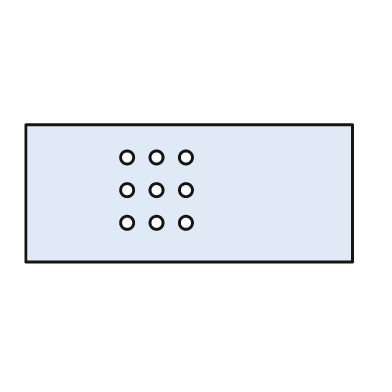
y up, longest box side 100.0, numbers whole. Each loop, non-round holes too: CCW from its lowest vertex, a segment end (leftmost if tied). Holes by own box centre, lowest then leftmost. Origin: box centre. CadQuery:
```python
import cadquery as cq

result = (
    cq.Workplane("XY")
    .moveTo(-50.0, -21.0)
    .lineTo(50.0, -21.0)
    .lineTo(50.0, 21.0)
    .lineTo(-50.0, 21.0)
    .close()
    .moveTo(-19.0, -9.0)
    .circle(2.0)
    .moveTo(-10.0, -9.0)
    .circle(2.0)
    .moveTo(-1.0, -9.0)
    .circle(2.0)
    .moveTo(-19.0, 1.0)
    .circle(2.0)
    .moveTo(-10.0, 1.0)
    .circle(2.0)
    .moveTo(-1.0, 1.0)
    .circle(2.0)
    .moveTo(-19.0, 11.0)
    .circle(2.0)
    .moveTo(-10.0, 11.0)
    .circle(2.0)
    .moveTo(-1.0, 11.0)
    .circle(2.0)
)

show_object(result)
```